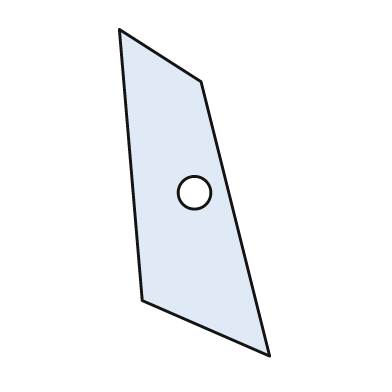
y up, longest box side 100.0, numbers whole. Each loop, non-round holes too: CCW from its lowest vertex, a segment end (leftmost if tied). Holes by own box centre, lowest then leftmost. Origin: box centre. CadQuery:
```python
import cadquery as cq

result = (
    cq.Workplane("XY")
    .moveTo(23.0, -50.0)
    .lineTo(2.0, 34.0)
    .lineTo(-23.0, 50.0)
    .lineTo(-16.0, -33.0)
    .close()
    .moveTo(0.0, 0.0)
    .circle(5.0)
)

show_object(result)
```